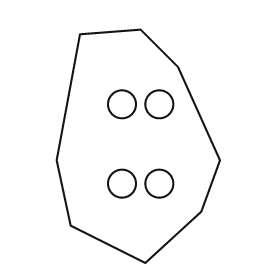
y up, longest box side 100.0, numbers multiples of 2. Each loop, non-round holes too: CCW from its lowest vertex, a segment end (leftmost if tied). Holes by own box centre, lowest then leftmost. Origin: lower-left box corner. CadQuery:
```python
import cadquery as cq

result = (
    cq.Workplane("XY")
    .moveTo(38.0, 0.0)
    .lineTo(62.0, 22.0)
    .lineTo(70.0, 44.0)
    .lineTo(52.0, 84.0)
    .lineTo(36.0, 100.0)
    .lineTo(10.0, 98.0)
    .lineTo(0.0, 44.0)
    .lineTo(6.0, 16.0)
    .close()
    .moveTo(28.0, 34.0)
    .circle(6.0)
    .moveTo(44.0, 34.0)
    .circle(6.0)
    .moveTo(28.0, 68.0)
    .circle(6.0)
    .moveTo(44.0, 68.0)
    .circle(6.0)
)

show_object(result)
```